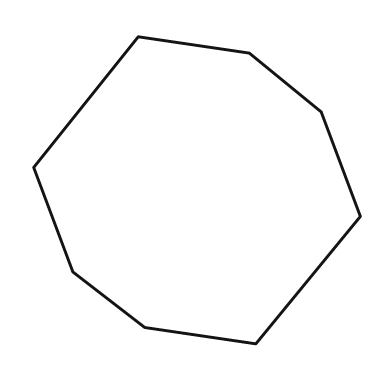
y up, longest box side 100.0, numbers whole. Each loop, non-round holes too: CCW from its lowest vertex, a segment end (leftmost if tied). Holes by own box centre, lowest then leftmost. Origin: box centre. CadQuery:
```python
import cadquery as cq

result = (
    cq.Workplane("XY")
    .moveTo(18.0, -47.0)
    .lineTo(50.0, -8.0)
    .lineTo(38.0, 24.0)
    .lineTo(16.0, 42.0)
    .lineTo(-18.0, 47.0)
    .lineTo(-50.0, 7.0)
    .lineTo(-38.0, -25.0)
    .lineTo(-16.0, -42.0)
    .close()
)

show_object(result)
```